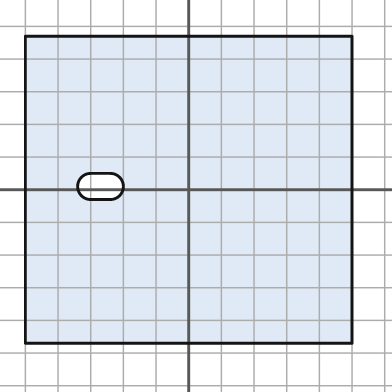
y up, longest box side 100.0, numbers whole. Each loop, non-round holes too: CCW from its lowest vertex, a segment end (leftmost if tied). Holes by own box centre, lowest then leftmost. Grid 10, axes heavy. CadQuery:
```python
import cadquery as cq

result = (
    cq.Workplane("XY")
    .moveTo(-50.0, -47.0)
    .lineTo(50.0, -47.0)
    .lineTo(50.0, 47.0)
    .lineTo(-50.0, 47.0)
    .close()
    .moveTo(-30.0, -3.0)
    .lineTo(-24.0, -3.0)
    .threePointArc((-20.0, 1.0), (-24.0, 5.0))
    .lineTo(-30.0, 5.0)
    .threePointArc((-34.0, 1.0), (-30.0, -3.0))
    .close()
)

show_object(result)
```